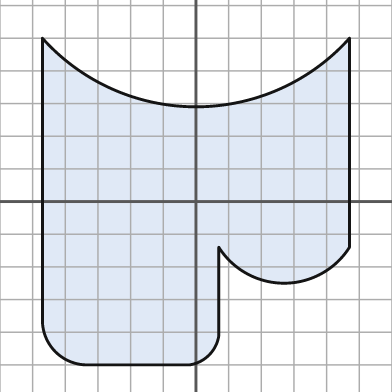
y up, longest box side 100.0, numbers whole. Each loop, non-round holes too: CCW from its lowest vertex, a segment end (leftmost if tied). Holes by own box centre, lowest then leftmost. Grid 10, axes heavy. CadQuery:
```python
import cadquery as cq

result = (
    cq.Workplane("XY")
    .moveTo(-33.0, -50.0)
    .lineTo(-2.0, -50.0)
    .threePointArc((4.0, -47.0), (7.0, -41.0))
    .lineTo(7.0, -14.0)
    .threePointArc((27.0, -25.0), (47.0, -14.0))
    .lineTo(47.0, 50.0)
    .threePointArc((0.0, 29.0), (-47.0, 50.0))
    .lineTo(-47.0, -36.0)
    .threePointArc((-43.0, -46.0), (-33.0, -50.0))
    .close()
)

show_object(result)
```